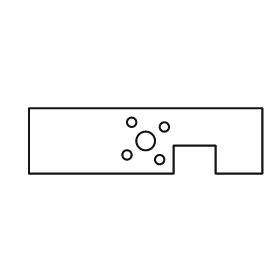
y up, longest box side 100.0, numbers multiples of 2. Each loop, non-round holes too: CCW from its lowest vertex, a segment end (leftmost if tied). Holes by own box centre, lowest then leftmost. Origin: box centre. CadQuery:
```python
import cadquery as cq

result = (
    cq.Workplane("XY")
    .moveTo(-50.0, -14.0)
    .lineTo(12.0, -14.0)
    .lineTo(12.0, -2.0)
    .lineTo(30.0, -2.0)
    .lineTo(30.0, -14.0)
    .lineTo(50.0, -14.0)
    .lineTo(50.0, 14.0)
    .lineTo(-50.0, 14.0)
    .close()
    .moveTo(6.0, -8.0)
    .circle(2.0)
    .moveTo(-8.0, -6.0)
    .circle(2.0)
    .moveTo(0.0, 0.0)
    .circle(4.0)
    .moveTo(8.0, 6.0)
    .circle(2.0)
    .moveTo(-6.0, 8.0)
    .circle(2.0)
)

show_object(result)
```